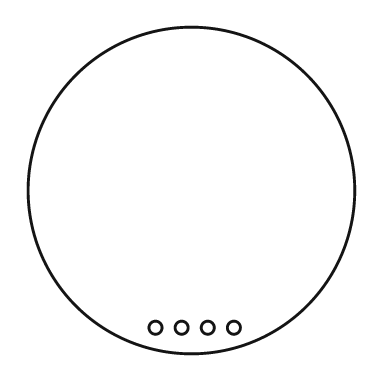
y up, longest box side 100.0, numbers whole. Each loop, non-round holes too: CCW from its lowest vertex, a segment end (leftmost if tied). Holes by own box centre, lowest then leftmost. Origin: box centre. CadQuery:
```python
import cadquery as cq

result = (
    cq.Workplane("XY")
    .moveTo(0.0, 0.0)
    .circle(50.0)
    .moveTo(-11.0, -42.0)
    .circle(2.0)
    .moveTo(-3.0, -42.0)
    .circle(2.0)
    .moveTo(5.0, -42.0)
    .circle(2.0)
    .moveTo(13.0, -42.0)
    .circle(2.0)
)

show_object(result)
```